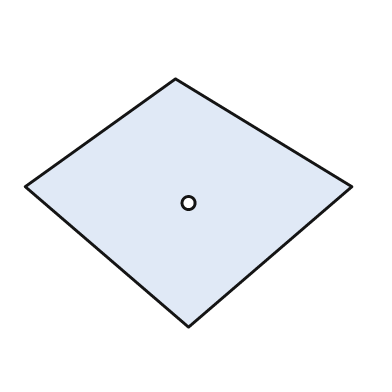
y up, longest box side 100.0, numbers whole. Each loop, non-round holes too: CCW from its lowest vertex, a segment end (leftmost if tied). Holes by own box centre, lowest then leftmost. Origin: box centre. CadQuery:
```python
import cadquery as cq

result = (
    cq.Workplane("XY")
    .moveTo(0.0, -38.0)
    .lineTo(50.0, 5.0)
    .lineTo(-4.0, 38.0)
    .lineTo(-50.0, 5.0)
    .close()
    .moveTo(0.0, 0.0)
    .circle(2.0)
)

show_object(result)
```